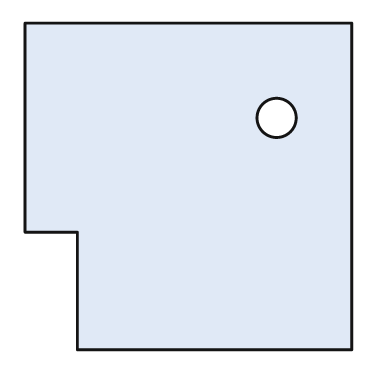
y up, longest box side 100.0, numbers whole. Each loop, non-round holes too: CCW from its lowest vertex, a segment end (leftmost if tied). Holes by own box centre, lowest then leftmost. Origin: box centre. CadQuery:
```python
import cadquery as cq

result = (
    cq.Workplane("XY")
    .moveTo(-34.0, -50.0)
    .lineTo(50.0, -50.0)
    .lineTo(50.0, 50.0)
    .lineTo(-50.0, 50.0)
    .lineTo(-50.0, -14.0)
    .lineTo(-34.0, -14.0)
    .close()
    .moveTo(27.0, 21.0)
    .circle(6.0)
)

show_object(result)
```